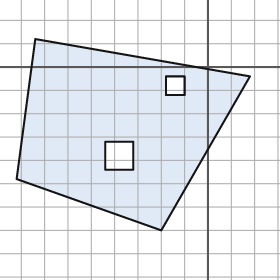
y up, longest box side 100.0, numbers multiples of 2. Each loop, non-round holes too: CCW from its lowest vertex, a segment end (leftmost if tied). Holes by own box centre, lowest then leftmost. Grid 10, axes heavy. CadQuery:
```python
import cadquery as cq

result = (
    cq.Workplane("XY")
    .moveTo(-20.0, -70.0)
    .lineTo(18.0, -4.0)
    .lineTo(-74.0, 12.0)
    .lineTo(-82.0, -48.0)
    .close()
    .moveTo(-44.0, -44.0)
    .lineTo(-32.0, -44.0)
    .lineTo(-32.0, -32.0)
    .lineTo(-44.0, -32.0)
    .close()
    .moveTo(-18.0, -12.0)
    .lineTo(-10.0, -12.0)
    .lineTo(-10.0, -4.0)
    .lineTo(-18.0, -4.0)
    .close()
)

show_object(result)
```